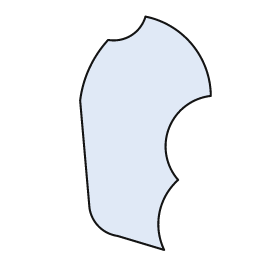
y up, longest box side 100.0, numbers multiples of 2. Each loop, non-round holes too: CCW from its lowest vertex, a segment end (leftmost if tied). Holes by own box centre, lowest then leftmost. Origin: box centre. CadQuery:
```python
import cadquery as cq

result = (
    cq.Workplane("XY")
    .moveTo(8.0, -50.0)
    .threePointArc((6.0, -34.0), (14.0, -20.0))
    .threePointArc((10.0, 2.0), (28.0, 16.0))
    .threePointArc((20.0, 38.0), (0.0, 50.0))
    .threePointArc((-6.0, 42.0), (-16.0, 40.0))
    .threePointArc((-24.0, 28.0), (-28.0, 14.0))
    .lineTo(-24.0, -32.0)
    .threePointArc((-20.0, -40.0), (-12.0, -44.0))
    .close()
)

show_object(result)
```